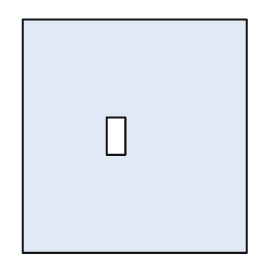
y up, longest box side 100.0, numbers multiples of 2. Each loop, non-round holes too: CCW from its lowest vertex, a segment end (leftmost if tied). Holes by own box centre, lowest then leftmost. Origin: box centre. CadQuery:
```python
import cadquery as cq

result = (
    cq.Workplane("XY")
    .moveTo(-48.0, -50.0)
    .lineTo(48.0, -50.0)
    .lineTo(48.0, 50.0)
    .lineTo(-48.0, 50.0)
    .close()
    .moveTo(-12.0, -8.0)
    .lineTo(-4.0, -8.0)
    .lineTo(-4.0, 8.0)
    .lineTo(-12.0, 8.0)
    .close()
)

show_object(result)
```